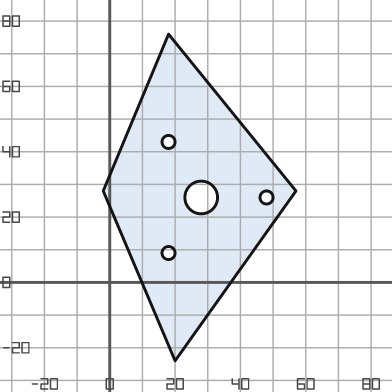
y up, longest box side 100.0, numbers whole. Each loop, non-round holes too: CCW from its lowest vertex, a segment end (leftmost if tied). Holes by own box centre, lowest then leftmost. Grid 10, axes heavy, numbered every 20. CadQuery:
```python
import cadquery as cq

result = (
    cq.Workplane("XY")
    .moveTo(20.0, -24.0)
    .lineTo(57.0, 28.0)
    .lineTo(18.0, 76.0)
    .lineTo(-2.0, 28.0)
    .close()
    .moveTo(18.0, 9.0)
    .circle(2.0)
    .moveTo(28.0, 26.0)
    .circle(5.0)
    .moveTo(48.0, 26.0)
    .circle(2.0)
    .moveTo(18.0, 43.0)
    .circle(2.0)
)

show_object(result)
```